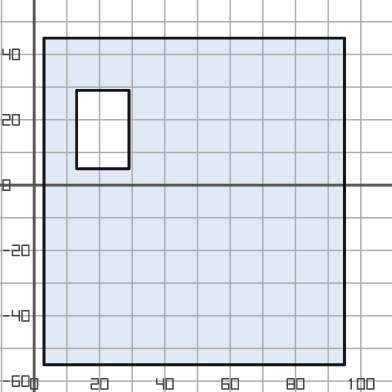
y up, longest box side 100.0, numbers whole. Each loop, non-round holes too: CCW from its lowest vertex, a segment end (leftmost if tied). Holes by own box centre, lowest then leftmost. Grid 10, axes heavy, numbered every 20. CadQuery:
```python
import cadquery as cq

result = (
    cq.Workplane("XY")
    .moveTo(3.0, -55.0)
    .lineTo(95.0, -55.0)
    .lineTo(95.0, 45.0)
    .lineTo(3.0, 45.0)
    .close()
    .moveTo(13.0, 5.0)
    .lineTo(29.0, 5.0)
    .lineTo(29.0, 29.0)
    .lineTo(13.0, 29.0)
    .close()
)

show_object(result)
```